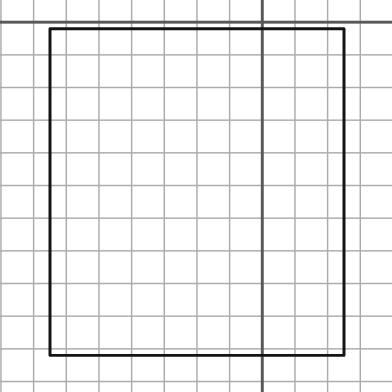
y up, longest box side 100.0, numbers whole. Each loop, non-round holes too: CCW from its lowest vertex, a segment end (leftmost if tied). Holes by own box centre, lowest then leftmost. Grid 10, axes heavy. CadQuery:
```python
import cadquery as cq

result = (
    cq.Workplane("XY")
    .moveTo(-65.0, -102.0)
    .lineTo(25.0, -102.0)
    .lineTo(25.0, -2.0)
    .lineTo(-65.0, -2.0)
    .close()
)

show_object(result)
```